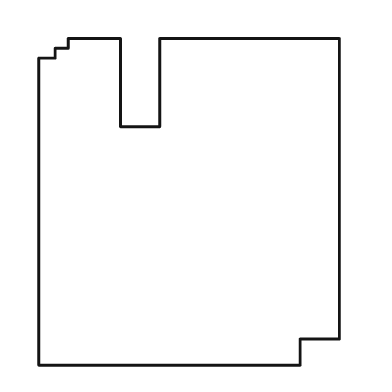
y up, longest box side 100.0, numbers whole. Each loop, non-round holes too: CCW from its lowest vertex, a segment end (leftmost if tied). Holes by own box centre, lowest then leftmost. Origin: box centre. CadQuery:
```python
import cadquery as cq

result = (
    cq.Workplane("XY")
    .moveTo(-46.0, -50.0)
    .lineTo(34.0, -50.0)
    .lineTo(34.0, -42.0)
    .lineTo(46.0, -42.0)
    .lineTo(46.0, 50.0)
    .lineTo(-9.0, 50.0)
    .lineTo(-9.0, 23.0)
    .lineTo(-21.0, 23.0)
    .lineTo(-21.0, 50.0)
    .lineTo(-37.0, 50.0)
    .lineTo(-37.0, 47.0)
    .lineTo(-41.0, 47.0)
    .lineTo(-41.0, 44.0)
    .lineTo(-46.0, 44.0)
    .close()
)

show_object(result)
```